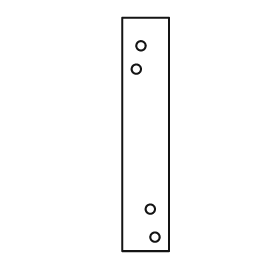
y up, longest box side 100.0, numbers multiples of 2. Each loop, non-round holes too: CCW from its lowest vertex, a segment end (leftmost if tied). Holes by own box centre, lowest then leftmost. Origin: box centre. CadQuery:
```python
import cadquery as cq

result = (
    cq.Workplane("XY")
    .moveTo(-10.0, -50.0)
    .lineTo(10.0, -50.0)
    .lineTo(10.0, 50.0)
    .lineTo(-10.0, 50.0)
    .close()
    .moveTo(4.0, -44.0)
    .circle(2.0)
    .moveTo(2.0, -32.0)
    .circle(2.0)
    .moveTo(-4.0, 28.0)
    .circle(2.0)
    .moveTo(-2.0, 38.0)
    .circle(2.0)
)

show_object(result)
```